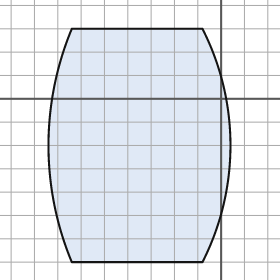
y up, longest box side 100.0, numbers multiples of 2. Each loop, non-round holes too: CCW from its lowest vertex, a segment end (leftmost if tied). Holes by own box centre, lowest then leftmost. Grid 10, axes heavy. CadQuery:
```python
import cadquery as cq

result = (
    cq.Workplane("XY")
    .moveTo(-64.0, -70.0)
    .lineTo(-8.0, -70.0)
    .threePointArc((4.0, -20.0), (-8.0, 30.0))
    .lineTo(-64.0, 30.0)
    .threePointArc((-74.0, -20.0), (-64.0, -70.0))
    .close()
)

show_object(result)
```